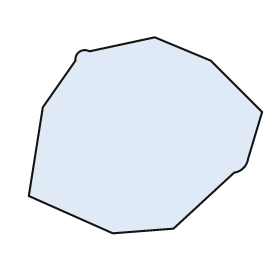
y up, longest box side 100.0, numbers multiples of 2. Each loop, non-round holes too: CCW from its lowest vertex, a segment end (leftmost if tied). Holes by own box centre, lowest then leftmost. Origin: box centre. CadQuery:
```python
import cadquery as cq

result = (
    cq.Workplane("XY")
    .moveTo(-14.0, -42.0)
    .lineTo(12.0, -40.0)
    .lineTo(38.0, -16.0)
    .threePointArc((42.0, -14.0), (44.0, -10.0))
    .lineTo(50.0, 10.0)
    .lineTo(28.0, 32.0)
    .lineTo(4.0, 42.0)
    .lineTo(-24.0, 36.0)
    .threePointArc((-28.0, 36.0), (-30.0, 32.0))
    .lineTo(-44.0, 12.0)
    .lineTo(-50.0, -26.0)
    .close()
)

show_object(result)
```